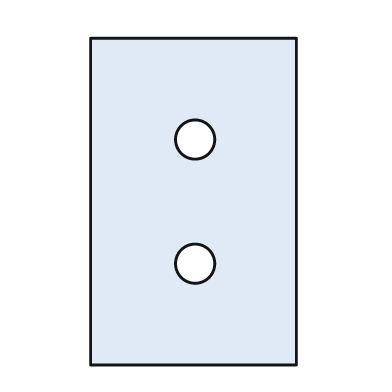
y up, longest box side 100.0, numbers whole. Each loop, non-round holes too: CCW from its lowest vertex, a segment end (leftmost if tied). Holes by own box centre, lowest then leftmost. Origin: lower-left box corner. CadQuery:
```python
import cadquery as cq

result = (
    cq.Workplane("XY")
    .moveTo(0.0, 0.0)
    .lineTo(63.0, 0.0)
    .lineTo(63.0, 100.0)
    .lineTo(0.0, 100.0)
    .close()
    .moveTo(32.0, 31.0)
    .circle(6.0)
    .moveTo(32.0, 69.0)
    .circle(6.0)
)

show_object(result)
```